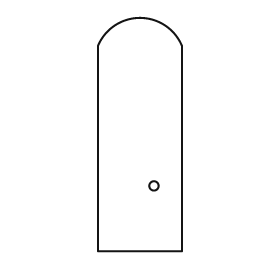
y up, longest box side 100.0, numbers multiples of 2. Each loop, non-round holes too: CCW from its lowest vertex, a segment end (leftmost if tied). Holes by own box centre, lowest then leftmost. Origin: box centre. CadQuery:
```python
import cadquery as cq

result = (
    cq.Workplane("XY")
    .moveTo(-18.0, -50.0)
    .lineTo(18.0, -50.0)
    .lineTo(18.0, 38.0)
    .threePointArc((0.0, 50.0), (-18.0, 38.0))
    .close()
    .moveTo(6.0, -22.0)
    .circle(2.0)
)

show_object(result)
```